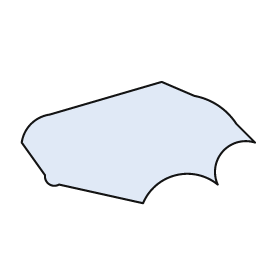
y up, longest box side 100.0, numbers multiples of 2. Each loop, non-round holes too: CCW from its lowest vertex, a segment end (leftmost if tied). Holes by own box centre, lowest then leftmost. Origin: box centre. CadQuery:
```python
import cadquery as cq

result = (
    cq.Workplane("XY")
    .moveTo(2.0, -26.0)
    .threePointArc((16.0, -14.0), (34.0, -18.0))
    .threePointArc((36.0, -4.0), (50.0, 0.0))
    .lineTo(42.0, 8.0)
    .threePointArc((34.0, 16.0), (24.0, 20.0))
    .lineTo(10.0, 26.0)
    .lineTo(-38.0, 12.0)
    .threePointArc((-46.0, 8.0), (-50.0, 0.0))
    .lineTo(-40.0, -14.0)
    .threePointArc((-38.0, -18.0), (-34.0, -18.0))
    .close()
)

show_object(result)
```